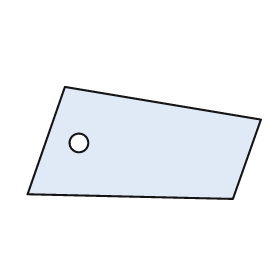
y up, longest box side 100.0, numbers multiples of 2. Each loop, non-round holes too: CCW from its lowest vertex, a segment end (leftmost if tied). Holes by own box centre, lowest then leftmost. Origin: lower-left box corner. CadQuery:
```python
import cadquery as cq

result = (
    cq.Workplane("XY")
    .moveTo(88.0, 0.0)
    .lineTo(100.0, 34.0)
    .lineTo(16.0, 48.0)
    .lineTo(0.0, 2.0)
    .close()
    .moveTo(22.0, 24.0)
    .circle(4.0)
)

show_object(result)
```